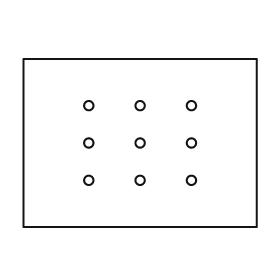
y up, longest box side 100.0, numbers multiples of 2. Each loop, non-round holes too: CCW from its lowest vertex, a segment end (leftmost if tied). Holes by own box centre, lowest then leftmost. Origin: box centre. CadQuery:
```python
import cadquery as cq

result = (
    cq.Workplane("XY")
    .moveTo(-50.0, -36.0)
    .lineTo(50.0, -36.0)
    .lineTo(50.0, 36.0)
    .lineTo(-50.0, 36.0)
    .close()
    .moveTo(-22.0, -16.0)
    .circle(2.0)
    .moveTo(0.0, -16.0)
    .circle(2.0)
    .moveTo(22.0, -16.0)
    .circle(2.0)
    .moveTo(-22.0, 0.0)
    .circle(2.0)
    .moveTo(0.0, 0.0)
    .circle(2.0)
    .moveTo(22.0, 0.0)
    .circle(2.0)
    .moveTo(-22.0, 16.0)
    .circle(2.0)
    .moveTo(0.0, 16.0)
    .circle(2.0)
    .moveTo(22.0, 16.0)
    .circle(2.0)
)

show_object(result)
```